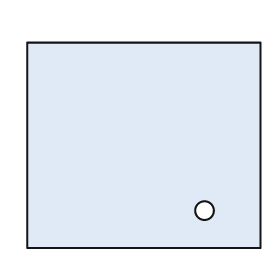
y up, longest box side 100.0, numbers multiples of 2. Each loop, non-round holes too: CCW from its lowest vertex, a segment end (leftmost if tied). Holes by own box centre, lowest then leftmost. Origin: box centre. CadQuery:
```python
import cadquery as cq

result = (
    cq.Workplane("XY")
    .moveTo(-50.0, -44.0)
    .lineTo(50.0, -44.0)
    .lineTo(50.0, 44.0)
    .lineTo(-50.0, 44.0)
    .close()
    .moveTo(26.0, -28.0)
    .circle(4.0)
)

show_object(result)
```